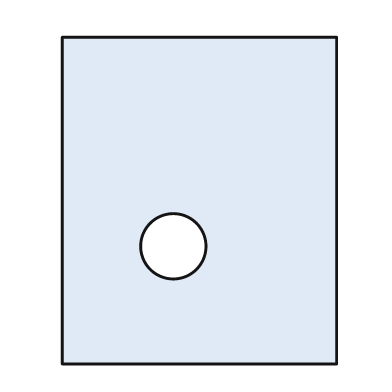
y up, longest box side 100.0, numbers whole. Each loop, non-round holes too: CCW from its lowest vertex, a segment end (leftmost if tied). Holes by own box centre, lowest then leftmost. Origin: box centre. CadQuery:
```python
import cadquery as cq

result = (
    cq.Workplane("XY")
    .moveTo(-42.0, -50.0)
    .lineTo(42.0, -50.0)
    .lineTo(42.0, 50.0)
    .lineTo(-42.0, 50.0)
    .close()
    .moveTo(-8.0, -14.0)
    .circle(10.0)
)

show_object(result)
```